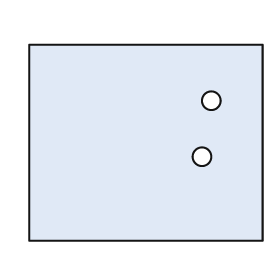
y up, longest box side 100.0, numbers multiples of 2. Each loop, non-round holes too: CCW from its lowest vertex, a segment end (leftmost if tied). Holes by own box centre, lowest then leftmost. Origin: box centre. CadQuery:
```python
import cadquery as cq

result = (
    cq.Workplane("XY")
    .moveTo(-50.0, -42.0)
    .lineTo(50.0, -42.0)
    .lineTo(50.0, 42.0)
    .lineTo(-50.0, 42.0)
    .close()
    .moveTo(24.0, -6.0)
    .circle(4.0)
    .moveTo(28.0, 18.0)
    .circle(4.0)
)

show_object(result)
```